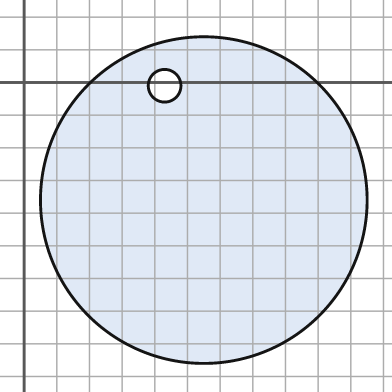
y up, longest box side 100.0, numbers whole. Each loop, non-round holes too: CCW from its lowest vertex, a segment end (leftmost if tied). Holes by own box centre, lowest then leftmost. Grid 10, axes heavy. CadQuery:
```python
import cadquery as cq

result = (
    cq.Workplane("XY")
    .moveTo(55.0, -36.0)
    .circle(50.0)
    .moveTo(43.0, -1.0)
    .circle(5.0)
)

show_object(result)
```